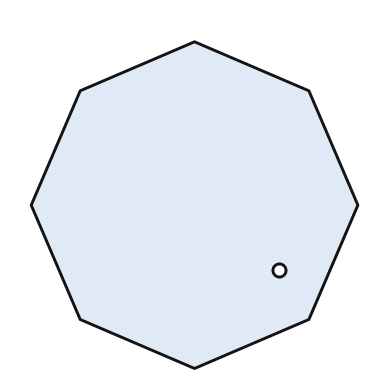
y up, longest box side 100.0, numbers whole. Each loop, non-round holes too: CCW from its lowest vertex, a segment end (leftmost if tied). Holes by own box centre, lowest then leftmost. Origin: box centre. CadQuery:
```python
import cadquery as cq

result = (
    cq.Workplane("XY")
    .moveTo(0.0, -50.0)
    .lineTo(35.0, -35.0)
    .lineTo(50.0, 0.0)
    .lineTo(35.0, 35.0)
    .lineTo(0.0, 50.0)
    .lineTo(-35.0, 35.0)
    .lineTo(-50.0, 0.0)
    .lineTo(-35.0, -35.0)
    .close()
    .moveTo(26.0, -20.0)
    .circle(2.0)
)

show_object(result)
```